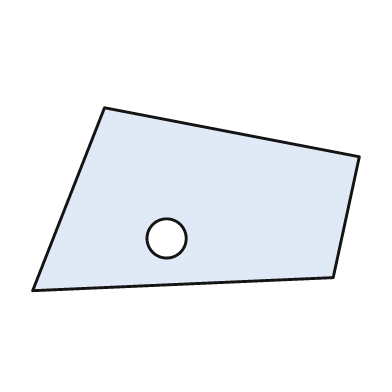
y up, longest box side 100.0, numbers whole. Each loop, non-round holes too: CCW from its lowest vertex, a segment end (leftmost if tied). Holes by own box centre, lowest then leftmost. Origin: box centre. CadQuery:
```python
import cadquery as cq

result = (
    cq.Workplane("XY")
    .moveTo(-50.0, -28.0)
    .lineTo(42.0, -24.0)
    .lineTo(50.0, 13.0)
    .lineTo(-28.0, 28.0)
    .close()
    .moveTo(-9.0, -12.0)
    .circle(6.0)
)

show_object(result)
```